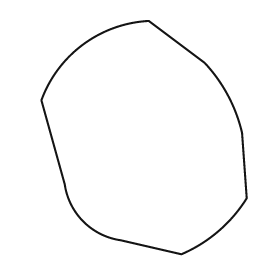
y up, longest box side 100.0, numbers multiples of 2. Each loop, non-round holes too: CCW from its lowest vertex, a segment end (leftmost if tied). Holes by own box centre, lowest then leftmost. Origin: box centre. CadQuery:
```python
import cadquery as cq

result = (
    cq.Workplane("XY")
    .moveTo(16.0, -50.0)
    .threePointArc((32.0, -40.0), (44.0, -26.0))
    .lineTo(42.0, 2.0)
    .threePointArc((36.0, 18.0), (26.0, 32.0))
    .lineTo(2.0, 50.0)
    .threePointArc((-26.0, 40.0), (-44.0, 16.0))
    .lineTo(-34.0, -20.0)
    .threePointArc((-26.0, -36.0), (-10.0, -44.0))
    .close()
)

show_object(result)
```